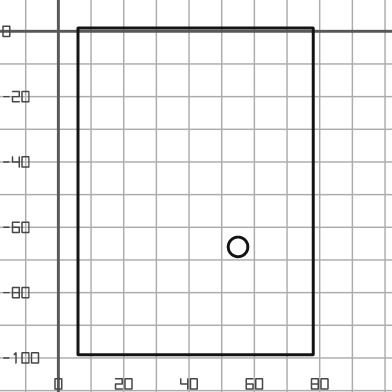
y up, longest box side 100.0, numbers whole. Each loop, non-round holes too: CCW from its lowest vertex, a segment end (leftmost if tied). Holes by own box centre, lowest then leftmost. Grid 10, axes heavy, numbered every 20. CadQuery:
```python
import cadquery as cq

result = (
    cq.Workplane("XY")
    .moveTo(6.0, -99.0)
    .lineTo(78.0, -99.0)
    .lineTo(78.0, 1.0)
    .lineTo(6.0, 1.0)
    .close()
    .moveTo(55.0, -66.0)
    .circle(3.0)
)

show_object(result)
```